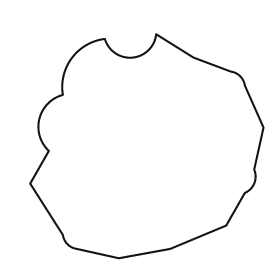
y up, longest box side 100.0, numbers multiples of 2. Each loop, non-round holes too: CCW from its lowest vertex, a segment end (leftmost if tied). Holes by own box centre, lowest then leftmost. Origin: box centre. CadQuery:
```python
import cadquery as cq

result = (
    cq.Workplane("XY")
    .moveTo(-12.0, -48.0)
    .lineTo(10.0, -44.0)
    .lineTo(34.0, -34.0)
    .lineTo(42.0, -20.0)
    .threePointArc((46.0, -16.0), (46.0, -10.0))
    .lineTo(50.0, 8.0)
    .lineTo(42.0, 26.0)
    .threePointArc((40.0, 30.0), (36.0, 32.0))
    .lineTo(20.0, 38.0)
    .lineTo(4.0, 48.0)
    .threePointArc((-6.0, 38.0), (-18.0, 46.0))
    .threePointArc((-32.0, 38.0), (-36.0, 22.0))
    .threePointArc((-46.0, 12.0), (-42.0, -2.0))
    .lineTo(-50.0, -16.0)
    .lineTo(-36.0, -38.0)
    .threePointArc((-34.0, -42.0), (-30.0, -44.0))
    .close()
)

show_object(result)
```